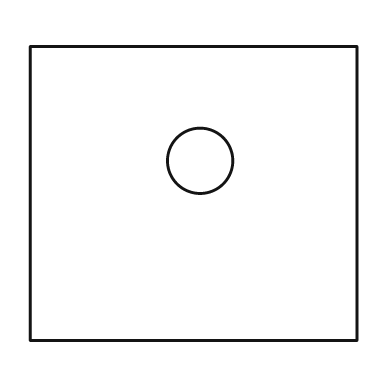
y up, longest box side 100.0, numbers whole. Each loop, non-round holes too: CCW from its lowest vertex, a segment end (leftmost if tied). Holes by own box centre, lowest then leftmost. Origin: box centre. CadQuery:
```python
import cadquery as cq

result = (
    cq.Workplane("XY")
    .moveTo(-50.0, -45.0)
    .lineTo(50.0, -45.0)
    .lineTo(50.0, 45.0)
    .lineTo(-50.0, 45.0)
    .close()
    .moveTo(2.0, 10.0)
    .circle(10.0)
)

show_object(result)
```